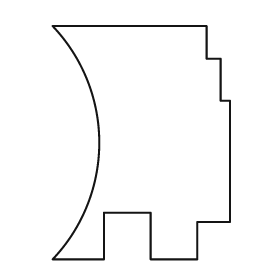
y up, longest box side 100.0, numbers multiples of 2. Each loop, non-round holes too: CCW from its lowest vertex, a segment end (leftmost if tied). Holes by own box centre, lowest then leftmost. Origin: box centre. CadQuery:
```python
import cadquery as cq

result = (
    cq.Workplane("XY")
    .moveTo(-38.0, -50.0)
    .lineTo(-16.0, -50.0)
    .lineTo(-16.0, -30.0)
    .lineTo(4.0, -30.0)
    .lineTo(4.0, -50.0)
    .lineTo(24.0, -50.0)
    .lineTo(24.0, -34.0)
    .lineTo(38.0, -34.0)
    .lineTo(38.0, 18.0)
    .lineTo(34.0, 18.0)
    .lineTo(34.0, 36.0)
    .lineTo(28.0, 36.0)
    .lineTo(28.0, 50.0)
    .lineTo(-38.0, 50.0)
    .threePointArc((-18.0, 0.0), (-38.0, -50.0))
    .close()
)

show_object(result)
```